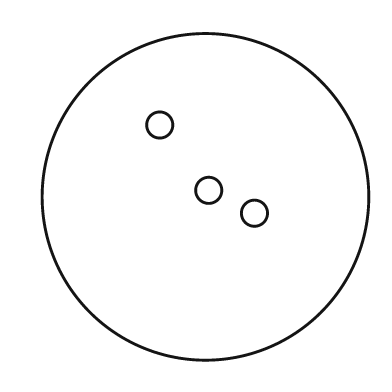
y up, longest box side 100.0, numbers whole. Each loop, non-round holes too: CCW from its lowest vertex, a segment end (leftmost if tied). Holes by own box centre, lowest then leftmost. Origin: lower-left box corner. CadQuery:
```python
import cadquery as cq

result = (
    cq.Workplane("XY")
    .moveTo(50.0, 50.0)
    .circle(50.0)
    .moveTo(65.0, 45.0)
    .circle(4.0)
    .moveTo(51.0, 52.0)
    .circle(4.0)
    .moveTo(36.0, 72.0)
    .circle(4.0)
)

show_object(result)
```